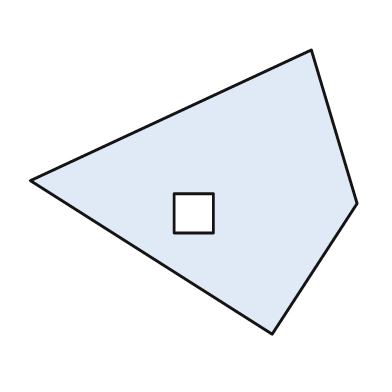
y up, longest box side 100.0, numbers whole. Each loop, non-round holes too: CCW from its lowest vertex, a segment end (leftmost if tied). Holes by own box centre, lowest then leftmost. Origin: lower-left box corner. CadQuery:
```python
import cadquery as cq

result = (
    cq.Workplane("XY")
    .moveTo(74.0, 0.0)
    .lineTo(100.0, 40.0)
    .lineTo(86.0, 87.0)
    .lineTo(0.0, 47.0)
    .close()
    .moveTo(44.0, 31.0)
    .lineTo(56.0, 31.0)
    .lineTo(56.0, 43.0)
    .lineTo(44.0, 43.0)
    .close()
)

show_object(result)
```